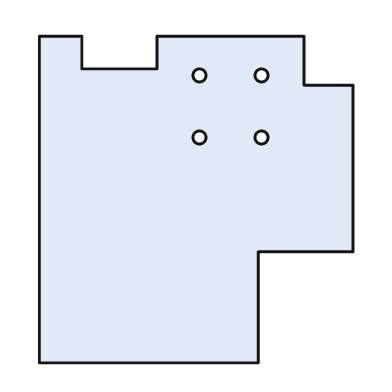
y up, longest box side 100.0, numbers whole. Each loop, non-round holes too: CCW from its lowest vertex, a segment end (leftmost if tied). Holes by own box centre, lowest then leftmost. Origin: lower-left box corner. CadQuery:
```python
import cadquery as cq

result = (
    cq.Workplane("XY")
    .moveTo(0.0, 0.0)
    .lineTo(67.0, 0.0)
    .lineTo(67.0, 34.0)
    .lineTo(96.0, 34.0)
    .lineTo(96.0, 85.0)
    .lineTo(81.0, 85.0)
    .lineTo(81.0, 100.0)
    .lineTo(36.0, 100.0)
    .lineTo(36.0, 90.0)
    .lineTo(13.0, 90.0)
    .lineTo(13.0, 100.0)
    .lineTo(0.0, 100.0)
    .close()
    .moveTo(49.0, 69.0)
    .circle(2.0)
    .moveTo(68.0, 69.0)
    .circle(2.0)
    .moveTo(49.0, 88.0)
    .circle(2.0)
    .moveTo(68.0, 88.0)
    .circle(2.0)
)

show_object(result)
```